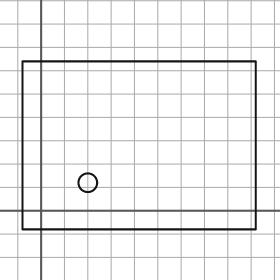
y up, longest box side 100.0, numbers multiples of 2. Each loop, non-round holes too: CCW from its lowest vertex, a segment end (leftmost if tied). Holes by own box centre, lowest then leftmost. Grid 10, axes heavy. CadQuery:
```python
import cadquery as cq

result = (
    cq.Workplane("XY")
    .moveTo(-8.0, -8.0)
    .lineTo(92.0, -8.0)
    .lineTo(92.0, 64.0)
    .lineTo(-8.0, 64.0)
    .close()
    .moveTo(20.0, 12.0)
    .circle(4.0)
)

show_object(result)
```